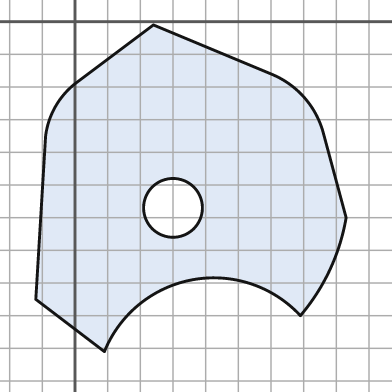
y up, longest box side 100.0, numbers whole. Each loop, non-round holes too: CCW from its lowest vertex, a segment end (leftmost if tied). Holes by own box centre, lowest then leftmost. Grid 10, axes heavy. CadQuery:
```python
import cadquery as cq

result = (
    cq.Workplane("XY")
    .moveTo(9.0, -101.0)
    .threePointArc((36.0, -79.0), (69.0, -90.0))
    .threePointArc((78.0, -76.0), (83.0, -60.0))
    .lineTo(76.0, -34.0)
    .threePointArc((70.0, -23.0), (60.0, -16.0))
    .lineTo(24.0, -1.0)
    .lineTo(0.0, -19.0)
    .threePointArc((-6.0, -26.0), (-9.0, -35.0))
    .lineTo(-12.0, -85.0)
    .close()
    .moveTo(30.0, -57.0)
    .circle(9.0)
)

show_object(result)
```